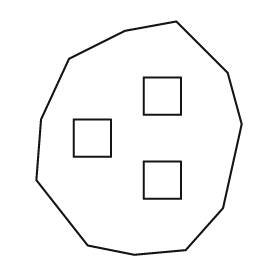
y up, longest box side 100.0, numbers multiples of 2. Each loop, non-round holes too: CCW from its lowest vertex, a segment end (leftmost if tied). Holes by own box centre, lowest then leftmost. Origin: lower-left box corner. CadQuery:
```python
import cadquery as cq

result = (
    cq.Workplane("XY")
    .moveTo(42.0, 0.0)
    .lineTo(64.0, 2.0)
    .lineTo(80.0, 20.0)
    .lineTo(88.0, 56.0)
    .lineTo(82.0, 78.0)
    .lineTo(60.0, 100.0)
    .lineTo(38.0, 96.0)
    .lineTo(14.0, 84.0)
    .lineTo(2.0, 58.0)
    .lineTo(0.0, 32.0)
    .lineTo(22.0, 4.0)
    .close()
    .moveTo(46.0, 24.0)
    .lineTo(62.0, 24.0)
    .lineTo(62.0, 40.0)
    .lineTo(46.0, 40.0)
    .close()
    .moveTo(16.0, 42.0)
    .lineTo(32.0, 42.0)
    .lineTo(32.0, 58.0)
    .lineTo(16.0, 58.0)
    .close()
    .moveTo(46.0, 60.0)
    .lineTo(62.0, 60.0)
    .lineTo(62.0, 76.0)
    .lineTo(46.0, 76.0)
    .close()
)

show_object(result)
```